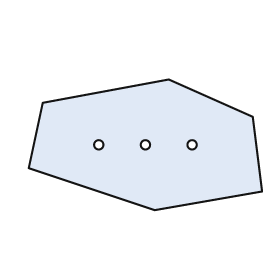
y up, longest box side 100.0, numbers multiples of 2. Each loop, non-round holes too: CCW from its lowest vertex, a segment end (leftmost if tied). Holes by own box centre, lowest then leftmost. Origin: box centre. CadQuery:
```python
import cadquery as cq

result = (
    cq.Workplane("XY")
    .moveTo(4.0, -28.0)
    .lineTo(50.0, -20.0)
    .lineTo(46.0, 12.0)
    .lineTo(10.0, 28.0)
    .lineTo(-44.0, 18.0)
    .lineTo(-50.0, -10.0)
    .close()
    .moveTo(-20.0, 0.0)
    .circle(2.0)
    .moveTo(0.0, 0.0)
    .circle(2.0)
    .moveTo(20.0, 0.0)
    .circle(2.0)
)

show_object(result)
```